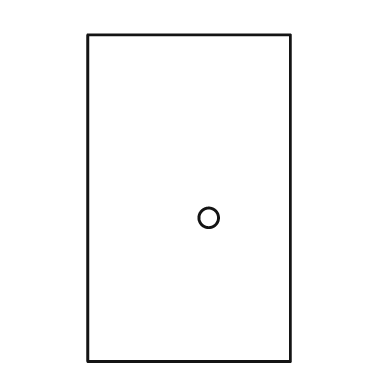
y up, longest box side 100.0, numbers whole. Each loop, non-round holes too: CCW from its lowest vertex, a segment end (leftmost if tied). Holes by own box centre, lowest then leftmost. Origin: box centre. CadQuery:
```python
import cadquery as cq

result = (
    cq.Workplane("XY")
    .moveTo(-31.0, -50.0)
    .lineTo(31.0, -50.0)
    .lineTo(31.0, 50.0)
    .lineTo(-31.0, 50.0)
    .close()
    .moveTo(6.0, -6.0)
    .circle(3.0)
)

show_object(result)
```